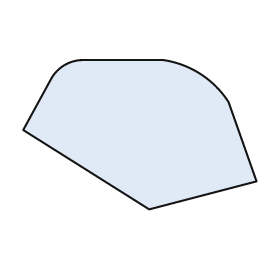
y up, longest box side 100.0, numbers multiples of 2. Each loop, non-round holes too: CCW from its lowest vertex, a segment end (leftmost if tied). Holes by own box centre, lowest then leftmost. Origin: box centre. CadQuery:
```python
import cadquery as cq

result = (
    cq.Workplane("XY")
    .moveTo(4.0, -32.0)
    .lineTo(50.0, -20.0)
    .lineTo(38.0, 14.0)
    .threePointArc((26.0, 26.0), (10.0, 32.0))
    .lineTo(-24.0, 32.0)
    .threePointArc((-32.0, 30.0), (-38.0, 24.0))
    .lineTo(-50.0, 2.0)
    .close()
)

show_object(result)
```